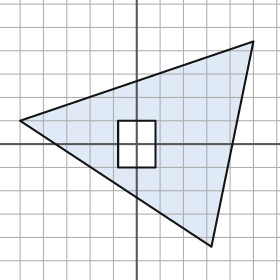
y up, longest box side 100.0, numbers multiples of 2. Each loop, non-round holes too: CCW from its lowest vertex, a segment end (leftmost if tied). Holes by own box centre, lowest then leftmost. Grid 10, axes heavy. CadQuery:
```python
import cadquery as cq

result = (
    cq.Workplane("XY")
    .moveTo(32.0, -44.0)
    .lineTo(50.0, 44.0)
    .lineTo(-50.0, 10.0)
    .close()
    .moveTo(-8.0, -10.0)
    .lineTo(8.0, -10.0)
    .lineTo(8.0, 10.0)
    .lineTo(-8.0, 10.0)
    .close()
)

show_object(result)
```